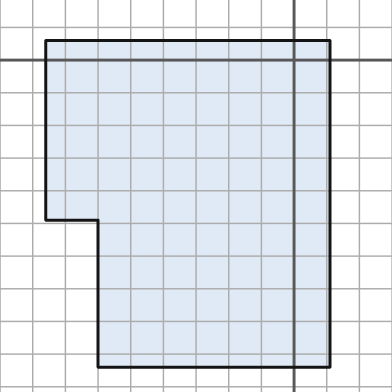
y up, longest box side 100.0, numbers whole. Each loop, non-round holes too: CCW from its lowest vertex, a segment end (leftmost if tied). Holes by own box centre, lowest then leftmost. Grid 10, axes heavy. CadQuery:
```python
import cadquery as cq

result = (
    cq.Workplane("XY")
    .moveTo(-60.0, -94.0)
    .lineTo(11.0, -94.0)
    .lineTo(11.0, 6.0)
    .lineTo(-76.0, 6.0)
    .lineTo(-76.0, -49.0)
    .lineTo(-60.0, -49.0)
    .close()
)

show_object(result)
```